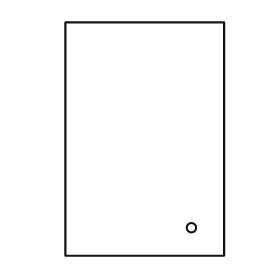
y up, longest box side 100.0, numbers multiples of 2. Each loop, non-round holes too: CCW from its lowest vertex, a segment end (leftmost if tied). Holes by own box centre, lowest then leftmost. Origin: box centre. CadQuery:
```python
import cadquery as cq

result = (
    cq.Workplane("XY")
    .moveTo(-34.0, -50.0)
    .lineTo(34.0, -50.0)
    .lineTo(34.0, 50.0)
    .lineTo(-34.0, 50.0)
    .close()
    .moveTo(20.0, -38.0)
    .circle(2.0)
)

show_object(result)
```